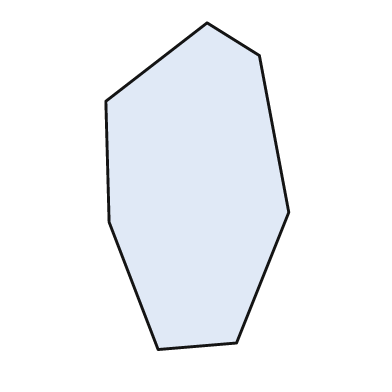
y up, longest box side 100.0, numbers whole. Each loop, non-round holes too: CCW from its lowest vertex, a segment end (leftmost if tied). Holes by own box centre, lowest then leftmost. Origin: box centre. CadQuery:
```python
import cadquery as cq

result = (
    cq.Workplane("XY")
    .moveTo(-12.0, -50.0)
    .lineTo(12.0, -48.0)
    .lineTo(28.0, -8.0)
    .lineTo(19.0, 40.0)
    .lineTo(3.0, 50.0)
    .lineTo(-28.0, 26.0)
    .lineTo(-27.0, -11.0)
    .close()
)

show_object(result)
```